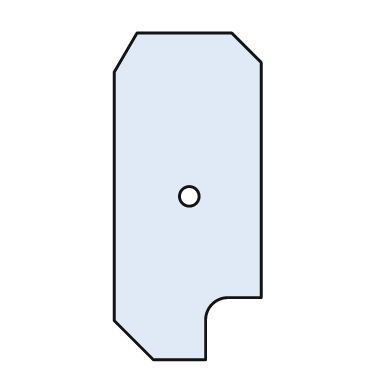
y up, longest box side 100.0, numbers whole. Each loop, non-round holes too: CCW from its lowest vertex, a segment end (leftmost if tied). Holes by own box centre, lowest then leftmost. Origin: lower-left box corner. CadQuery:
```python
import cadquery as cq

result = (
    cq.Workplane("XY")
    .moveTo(12.0, 0.0)
    .lineTo(28.0, 0.0)
    .lineTo(28.0, 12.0)
    .threePointArc((30.0, 17.0), (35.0, 19.0))
    .lineTo(45.0, 19.0)
    .lineTo(45.0, 91.0)
    .lineTo(36.0, 100.0)
    .lineTo(7.0, 100.0)
    .lineTo(0.0, 88.0)
    .lineTo(0.0, 12.0)
    .close()
    .moveTo(23.0, 50.0)
    .circle(3.0)
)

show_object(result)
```